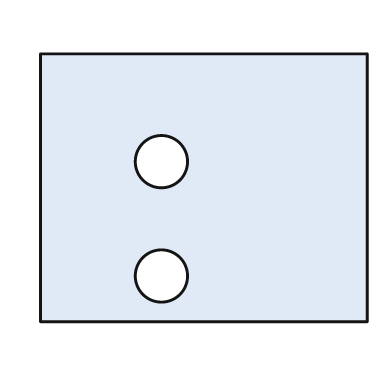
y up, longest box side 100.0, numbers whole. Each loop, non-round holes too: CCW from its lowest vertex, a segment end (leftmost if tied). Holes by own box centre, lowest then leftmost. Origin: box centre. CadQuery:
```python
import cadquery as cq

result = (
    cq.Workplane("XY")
    .moveTo(-50.0, -41.0)
    .lineTo(50.0, -41.0)
    .lineTo(50.0, 41.0)
    .lineTo(-50.0, 41.0)
    .close()
    .moveTo(-13.0, -27.0)
    .circle(8.0)
    .moveTo(-13.0, 8.0)
    .circle(8.0)
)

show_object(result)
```